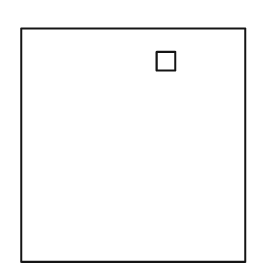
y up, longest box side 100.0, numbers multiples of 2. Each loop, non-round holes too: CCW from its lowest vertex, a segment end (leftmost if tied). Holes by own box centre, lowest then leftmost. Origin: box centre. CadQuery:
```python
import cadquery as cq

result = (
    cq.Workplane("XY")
    .moveTo(-48.0, -50.0)
    .lineTo(48.0, -50.0)
    .lineTo(48.0, 50.0)
    .lineTo(-48.0, 50.0)
    .close()
    .moveTo(10.0, 32.0)
    .lineTo(18.0, 32.0)
    .lineTo(18.0, 40.0)
    .lineTo(10.0, 40.0)
    .close()
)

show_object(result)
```